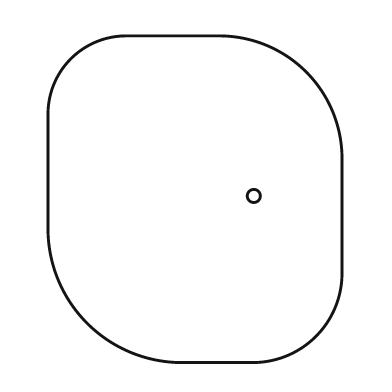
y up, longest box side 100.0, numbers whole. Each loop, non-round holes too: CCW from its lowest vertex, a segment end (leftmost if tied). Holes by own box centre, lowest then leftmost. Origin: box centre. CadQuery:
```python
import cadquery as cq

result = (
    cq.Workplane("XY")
    .moveTo(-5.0, -50.0)
    .lineTo(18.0, -50.0)
    .threePointArc((37.0, -42.0), (45.0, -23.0))
    .lineTo(45.0, 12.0)
    .threePointArc((34.0, 39.0), (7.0, 50.0))
    .lineTo(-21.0, 50.0)
    .threePointArc((-38.0, 43.0), (-45.0, 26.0))
    .lineTo(-45.0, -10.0)
    .threePointArc((-33.0, -38.0), (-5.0, -50.0))
    .close()
    .moveTo(18.0, 1.0)
    .circle(2.0)
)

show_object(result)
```